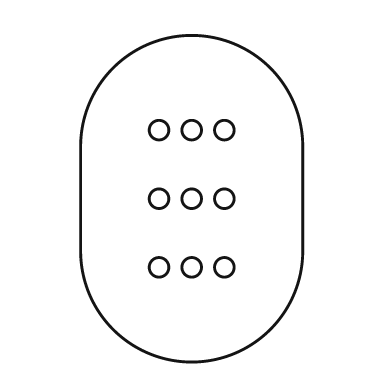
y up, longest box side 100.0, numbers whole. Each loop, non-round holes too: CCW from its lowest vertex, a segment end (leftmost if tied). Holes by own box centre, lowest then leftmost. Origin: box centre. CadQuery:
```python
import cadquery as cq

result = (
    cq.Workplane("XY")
    .moveTo(-34.0, -16.0)
    .threePointArc((0.0, -50.0), (34.0, -16.0))
    .lineTo(34.0, 16.0)
    .threePointArc((0.0, 50.0), (-34.0, 16.0))
    .close()
    .moveTo(-10.0, -21.0)
    .circle(3.0)
    .moveTo(0.0, -21.0)
    .circle(3.0)
    .moveTo(10.0, -21.0)
    .circle(3.0)
    .moveTo(-10.0, 0.0)
    .circle(3.0)
    .moveTo(0.0, 0.0)
    .circle(3.0)
    .moveTo(10.0, 0.0)
    .circle(3.0)
    .moveTo(-10.0, 21.0)
    .circle(3.0)
    .moveTo(0.0, 21.0)
    .circle(3.0)
    .moveTo(10.0, 21.0)
    .circle(3.0)
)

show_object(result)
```